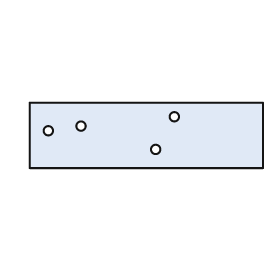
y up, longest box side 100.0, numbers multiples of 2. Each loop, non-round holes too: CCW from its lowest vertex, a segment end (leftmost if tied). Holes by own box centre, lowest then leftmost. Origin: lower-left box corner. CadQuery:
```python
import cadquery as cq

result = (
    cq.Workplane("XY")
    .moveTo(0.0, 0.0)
    .lineTo(100.0, 0.0)
    .lineTo(100.0, 28.0)
    .lineTo(0.0, 28.0)
    .close()
    .moveTo(54.0, 8.0)
    .circle(2.0)
    .moveTo(8.0, 16.0)
    .circle(2.0)
    .moveTo(22.0, 18.0)
    .circle(2.0)
    .moveTo(62.0, 22.0)
    .circle(2.0)
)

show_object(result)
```